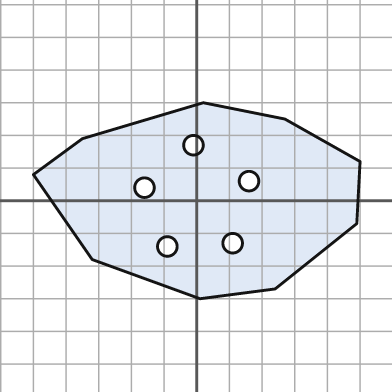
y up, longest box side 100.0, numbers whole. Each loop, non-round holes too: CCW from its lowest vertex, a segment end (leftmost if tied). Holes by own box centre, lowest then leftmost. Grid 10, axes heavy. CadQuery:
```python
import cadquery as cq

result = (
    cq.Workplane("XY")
    .moveTo(1.0, -30.0)
    .lineTo(24.0, -27.0)
    .lineTo(49.0, -7.0)
    .lineTo(50.0, 12.0)
    .lineTo(27.0, 25.0)
    .lineTo(2.0, 30.0)
    .lineTo(-35.0, 19.0)
    .lineTo(-50.0, 8.0)
    .lineTo(-32.0, -18.0)
    .close()
    .moveTo(-9.0, -14.0)
    .circle(3.0)
    .moveTo(11.0, -13.0)
    .circle(3.0)
    .moveTo(-16.0, 4.0)
    .circle(3.0)
    .moveTo(16.0, 6.0)
    .circle(3.0)
    .moveTo(-1.0, 17.0)
    .circle(3.0)
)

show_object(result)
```